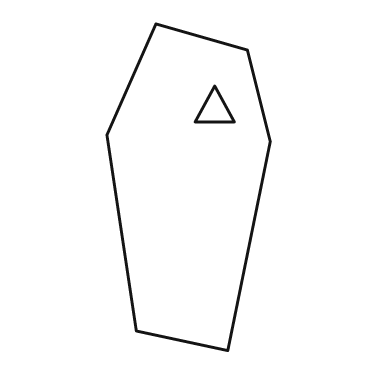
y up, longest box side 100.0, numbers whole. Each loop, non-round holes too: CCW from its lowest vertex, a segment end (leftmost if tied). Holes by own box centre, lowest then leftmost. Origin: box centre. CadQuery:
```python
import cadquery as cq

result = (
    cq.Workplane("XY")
    .moveTo(12.0, -50.0)
    .lineTo(25.0, 14.0)
    .lineTo(18.0, 42.0)
    .lineTo(-10.0, 50.0)
    .lineTo(-25.0, 16.0)
    .lineTo(-16.0, -44.0)
    .close()
    .moveTo(2.0, 20.0)
    .lineTo(14.0, 20.0)
    .lineTo(8.0, 31.0)
    .close()
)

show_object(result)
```